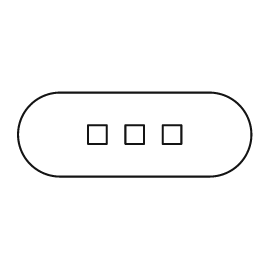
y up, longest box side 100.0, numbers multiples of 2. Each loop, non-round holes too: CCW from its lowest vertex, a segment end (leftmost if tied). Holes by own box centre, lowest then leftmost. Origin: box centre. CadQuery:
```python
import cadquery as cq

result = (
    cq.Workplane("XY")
    .moveTo(-32.0, -18.0)
    .lineTo(32.0, -18.0)
    .threePointArc((50.0, 0.0), (32.0, 18.0))
    .lineTo(-32.0, 18.0)
    .threePointArc((-50.0, 0.0), (-32.0, -18.0))
    .close()
    .moveTo(-20.0, -4.0)
    .lineTo(-12.0, -4.0)
    .lineTo(-12.0, 4.0)
    .lineTo(-20.0, 4.0)
    .close()
    .moveTo(-4.0, -4.0)
    .lineTo(4.0, -4.0)
    .lineTo(4.0, 4.0)
    .lineTo(-4.0, 4.0)
    .close()
    .moveTo(12.0, -4.0)
    .lineTo(20.0, -4.0)
    .lineTo(20.0, 4.0)
    .lineTo(12.0, 4.0)
    .close()
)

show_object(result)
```